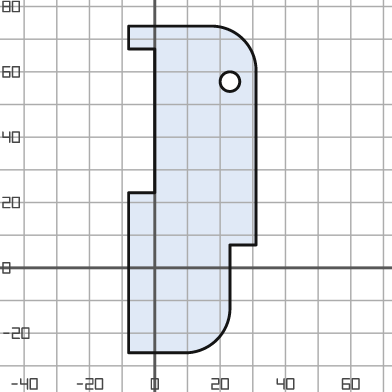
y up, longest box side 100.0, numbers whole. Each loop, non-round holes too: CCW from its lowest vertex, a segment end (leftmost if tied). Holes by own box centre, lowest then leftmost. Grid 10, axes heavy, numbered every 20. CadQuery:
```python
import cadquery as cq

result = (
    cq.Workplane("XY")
    .moveTo(-8.0, -26.0)
    .lineTo(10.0, -26.0)
    .threePointArc((19.0, -22.0), (23.0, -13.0))
    .lineTo(23.0, 7.0)
    .lineTo(31.0, 7.0)
    .lineTo(31.0, 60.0)
    .threePointArc((27.0, 70.0), (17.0, 74.0))
    .lineTo(-8.0, 74.0)
    .lineTo(-8.0, 67.0)
    .lineTo(0.0, 67.0)
    .lineTo(0.0, 23.0)
    .lineTo(-8.0, 23.0)
    .close()
    .moveTo(23.0, 57.0)
    .circle(3.0)
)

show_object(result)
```